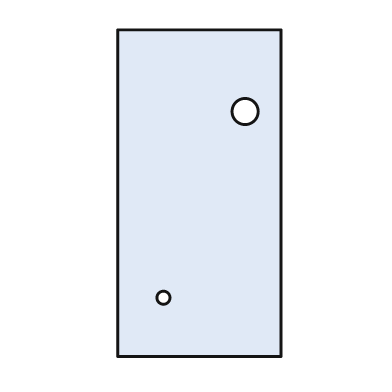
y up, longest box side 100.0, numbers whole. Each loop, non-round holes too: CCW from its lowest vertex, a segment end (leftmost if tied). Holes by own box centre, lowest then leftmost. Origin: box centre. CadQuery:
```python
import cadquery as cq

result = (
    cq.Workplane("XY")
    .moveTo(-25.0, -50.0)
    .lineTo(25.0, -50.0)
    .lineTo(25.0, 50.0)
    .lineTo(-25.0, 50.0)
    .close()
    .moveTo(-11.0, -32.0)
    .circle(2.0)
    .moveTo(14.0, 25.0)
    .circle(4.0)
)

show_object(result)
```